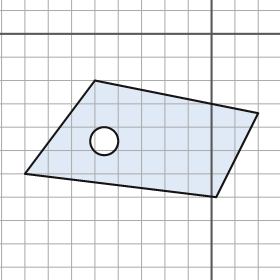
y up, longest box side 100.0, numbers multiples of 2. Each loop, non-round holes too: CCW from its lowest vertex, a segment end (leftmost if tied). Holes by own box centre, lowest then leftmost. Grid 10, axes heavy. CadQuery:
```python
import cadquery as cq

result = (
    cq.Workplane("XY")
    .moveTo(2.0, -70.0)
    .lineTo(20.0, -34.0)
    .lineTo(-50.0, -20.0)
    .lineTo(-80.0, -60.0)
    .close()
    .moveTo(-46.0, -46.0)
    .circle(6.0)
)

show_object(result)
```